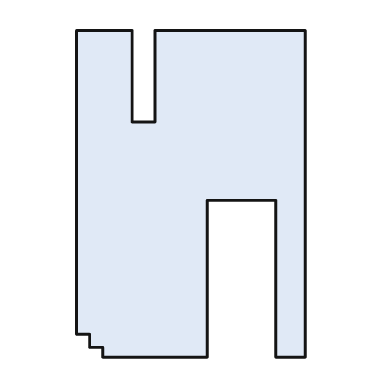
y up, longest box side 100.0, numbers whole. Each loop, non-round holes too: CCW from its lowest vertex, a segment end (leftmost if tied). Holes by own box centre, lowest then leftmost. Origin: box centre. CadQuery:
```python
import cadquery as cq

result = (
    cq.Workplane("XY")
    .moveTo(-27.0, -50.0)
    .lineTo(5.0, -50.0)
    .lineTo(5.0, -2.0)
    .lineTo(26.0, -2.0)
    .lineTo(26.0, -50.0)
    .lineTo(35.0, -50.0)
    .lineTo(35.0, 50.0)
    .lineTo(-11.0, 50.0)
    .lineTo(-11.0, 22.0)
    .lineTo(-18.0, 22.0)
    .lineTo(-18.0, 50.0)
    .lineTo(-35.0, 50.0)
    .lineTo(-35.0, -43.0)
    .lineTo(-31.0, -43.0)
    .lineTo(-31.0, -47.0)
    .lineTo(-27.0, -47.0)
    .close()
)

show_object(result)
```